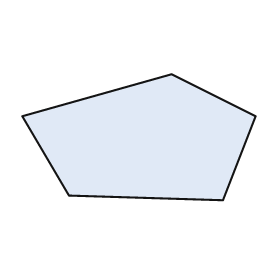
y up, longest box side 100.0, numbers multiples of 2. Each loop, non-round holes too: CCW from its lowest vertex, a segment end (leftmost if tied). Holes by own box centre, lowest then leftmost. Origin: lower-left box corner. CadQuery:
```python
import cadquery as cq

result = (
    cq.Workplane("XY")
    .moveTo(86.0, 0.0)
    .lineTo(100.0, 36.0)
    .lineTo(64.0, 54.0)
    .lineTo(0.0, 36.0)
    .lineTo(20.0, 2.0)
    .close()
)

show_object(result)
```